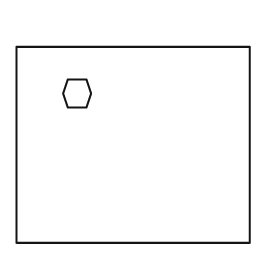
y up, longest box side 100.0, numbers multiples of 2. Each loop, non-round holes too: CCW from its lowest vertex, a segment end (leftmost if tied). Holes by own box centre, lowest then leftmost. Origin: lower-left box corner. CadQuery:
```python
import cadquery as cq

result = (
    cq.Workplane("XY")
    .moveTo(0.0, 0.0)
    .lineTo(100.0, 0.0)
    .lineTo(100.0, 84.0)
    .lineTo(0.0, 84.0)
    .close()
    .moveTo(22.0, 58.0)
    .lineTo(30.0, 58.0)
    .lineTo(32.0, 64.0)
    .lineTo(30.0, 70.0)
    .lineTo(22.0, 70.0)
    .lineTo(20.0, 64.0)
    .close()
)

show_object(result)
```